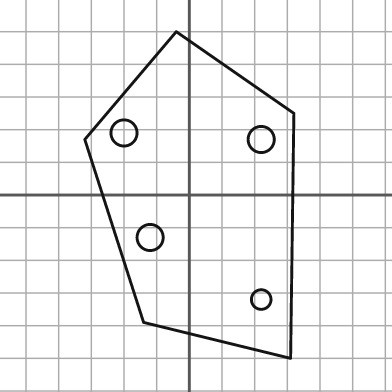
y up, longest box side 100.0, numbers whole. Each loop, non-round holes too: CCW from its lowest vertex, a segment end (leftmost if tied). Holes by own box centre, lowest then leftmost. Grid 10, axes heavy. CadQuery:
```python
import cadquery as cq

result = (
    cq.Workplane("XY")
    .moveTo(31.0, -50.0)
    .lineTo(32.0, 25.0)
    .lineTo(-4.0, 50.0)
    .lineTo(-32.0, 17.0)
    .lineTo(-14.0, -39.0)
    .close()
    .moveTo(22.0, -32.0)
    .circle(3.0)
    .moveTo(-12.0, -13.0)
    .circle(4.0)
    .moveTo(22.0, 17.0)
    .circle(4.0)
    .moveTo(-20.0, 19.0)
    .circle(4.0)
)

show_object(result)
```